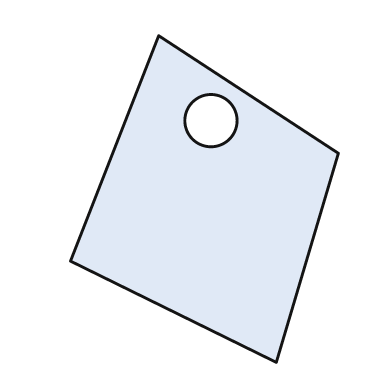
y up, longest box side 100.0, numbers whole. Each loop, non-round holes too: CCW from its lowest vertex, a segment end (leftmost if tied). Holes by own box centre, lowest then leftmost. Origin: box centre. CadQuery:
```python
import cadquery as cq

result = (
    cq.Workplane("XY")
    .moveTo(22.0, -50.0)
    .lineTo(41.0, 14.0)
    .lineTo(-14.0, 50.0)
    .lineTo(-41.0, -19.0)
    .close()
    .moveTo(2.0, 24.0)
    .circle(8.0)
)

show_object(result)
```